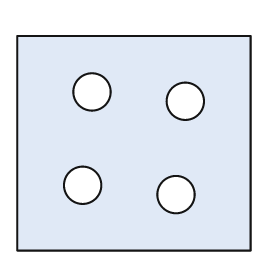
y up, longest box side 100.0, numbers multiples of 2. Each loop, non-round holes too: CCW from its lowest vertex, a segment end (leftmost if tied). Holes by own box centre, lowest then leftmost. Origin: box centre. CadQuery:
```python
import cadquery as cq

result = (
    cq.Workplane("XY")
    .moveTo(-50.0, -46.0)
    .lineTo(50.0, -46.0)
    .lineTo(50.0, 46.0)
    .lineTo(-50.0, 46.0)
    .close()
    .moveTo(18.0, -22.0)
    .circle(8.0)
    .moveTo(-22.0, -18.0)
    .circle(8.0)
    .moveTo(22.0, 18.0)
    .circle(8.0)
    .moveTo(-18.0, 22.0)
    .circle(8.0)
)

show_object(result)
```